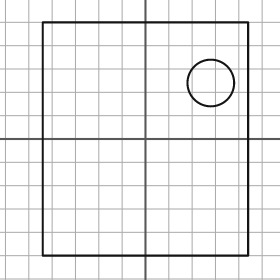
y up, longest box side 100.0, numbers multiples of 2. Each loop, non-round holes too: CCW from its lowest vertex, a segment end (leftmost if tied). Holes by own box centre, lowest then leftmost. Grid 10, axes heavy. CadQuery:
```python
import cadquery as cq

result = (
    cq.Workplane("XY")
    .moveTo(-44.0, -50.0)
    .lineTo(44.0, -50.0)
    .lineTo(44.0, 50.0)
    .lineTo(-44.0, 50.0)
    .close()
    .moveTo(28.0, 24.0)
    .circle(10.0)
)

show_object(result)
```